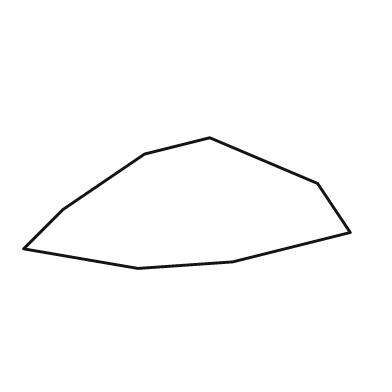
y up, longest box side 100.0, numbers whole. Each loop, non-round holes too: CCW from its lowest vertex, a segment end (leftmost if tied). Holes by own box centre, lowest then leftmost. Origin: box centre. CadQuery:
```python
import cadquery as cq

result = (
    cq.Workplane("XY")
    .moveTo(-15.0, -20.0)
    .lineTo(14.0, -18.0)
    .lineTo(50.0, -9.0)
    .lineTo(40.0, 6.0)
    .lineTo(7.0, 20.0)
    .lineTo(-13.0, 15.0)
    .lineTo(-38.0, -2.0)
    .lineTo(-50.0, -14.0)
    .close()
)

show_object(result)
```